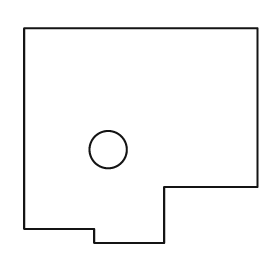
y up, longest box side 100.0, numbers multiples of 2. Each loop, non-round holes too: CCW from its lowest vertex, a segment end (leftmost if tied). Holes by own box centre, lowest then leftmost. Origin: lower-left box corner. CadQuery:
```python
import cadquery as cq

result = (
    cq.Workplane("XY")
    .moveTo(30.0, 0.0)
    .lineTo(60.0, 0.0)
    .lineTo(60.0, 24.0)
    .lineTo(100.0, 24.0)
    .lineTo(100.0, 92.0)
    .lineTo(0.0, 92.0)
    .lineTo(0.0, 6.0)
    .lineTo(30.0, 6.0)
    .close()
    .moveTo(36.0, 40.0)
    .circle(8.0)
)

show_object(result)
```